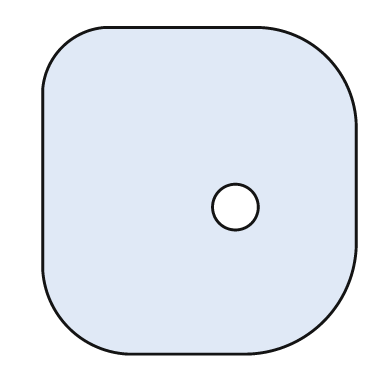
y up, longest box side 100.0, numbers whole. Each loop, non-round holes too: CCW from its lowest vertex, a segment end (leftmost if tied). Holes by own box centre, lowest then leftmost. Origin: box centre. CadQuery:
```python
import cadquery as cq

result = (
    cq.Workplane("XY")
    .moveTo(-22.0, -50.0)
    .lineTo(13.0, -50.0)
    .threePointArc((38.0, -40.0), (48.0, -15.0))
    .lineTo(48.0, 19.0)
    .threePointArc((39.0, 41.0), (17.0, 50.0))
    .lineTo(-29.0, 50.0)
    .threePointArc((-42.0, 44.0), (-48.0, 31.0))
    .lineTo(-48.0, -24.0)
    .threePointArc((-40.0, -42.0), (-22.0, -50.0))
    .close()
    .moveTo(11.0, -5.0)
    .circle(7.0)
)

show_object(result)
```